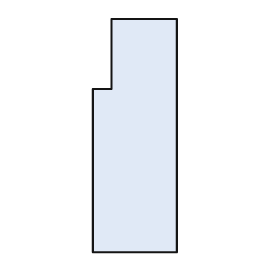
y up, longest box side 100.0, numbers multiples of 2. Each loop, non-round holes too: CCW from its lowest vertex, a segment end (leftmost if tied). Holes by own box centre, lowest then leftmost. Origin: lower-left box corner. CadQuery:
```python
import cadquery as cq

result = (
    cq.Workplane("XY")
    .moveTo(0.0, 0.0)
    .lineTo(36.0, 0.0)
    .lineTo(36.0, 100.0)
    .lineTo(8.0, 100.0)
    .lineTo(8.0, 70.0)
    .lineTo(0.0, 70.0)
    .close()
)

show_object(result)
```